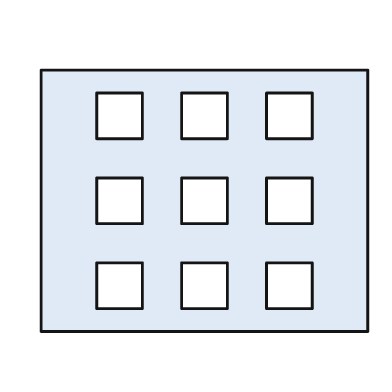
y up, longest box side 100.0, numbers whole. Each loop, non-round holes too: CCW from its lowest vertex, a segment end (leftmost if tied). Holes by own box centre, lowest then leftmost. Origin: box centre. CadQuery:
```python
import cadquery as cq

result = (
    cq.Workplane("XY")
    .moveTo(-50.0, -40.0)
    .lineTo(50.0, -40.0)
    .lineTo(50.0, 40.0)
    .lineTo(-50.0, 40.0)
    .close()
    .moveTo(-33.0, -33.0)
    .lineTo(-19.0, -33.0)
    .lineTo(-19.0, -19.0)
    .lineTo(-33.0, -19.0)
    .close()
    .moveTo(-7.0, -33.0)
    .lineTo(7.0, -33.0)
    .lineTo(7.0, -19.0)
    .lineTo(-7.0, -19.0)
    .close()
    .moveTo(19.0, -33.0)
    .lineTo(33.0, -33.0)
    .lineTo(33.0, -19.0)
    .lineTo(19.0, -19.0)
    .close()
    .moveTo(-33.0, -7.0)
    .lineTo(-19.0, -7.0)
    .lineTo(-19.0, 7.0)
    .lineTo(-33.0, 7.0)
    .close()
    .moveTo(-7.0, -7.0)
    .lineTo(7.0, -7.0)
    .lineTo(7.0, 7.0)
    .lineTo(-7.0, 7.0)
    .close()
    .moveTo(19.0, -7.0)
    .lineTo(33.0, -7.0)
    .lineTo(33.0, 7.0)
    .lineTo(19.0, 7.0)
    .close()
    .moveTo(-33.0, 19.0)
    .lineTo(-19.0, 19.0)
    .lineTo(-19.0, 33.0)
    .lineTo(-33.0, 33.0)
    .close()
    .moveTo(-7.0, 19.0)
    .lineTo(7.0, 19.0)
    .lineTo(7.0, 33.0)
    .lineTo(-7.0, 33.0)
    .close()
    .moveTo(19.0, 19.0)
    .lineTo(33.0, 19.0)
    .lineTo(33.0, 33.0)
    .lineTo(19.0, 33.0)
    .close()
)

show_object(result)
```